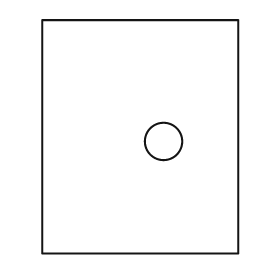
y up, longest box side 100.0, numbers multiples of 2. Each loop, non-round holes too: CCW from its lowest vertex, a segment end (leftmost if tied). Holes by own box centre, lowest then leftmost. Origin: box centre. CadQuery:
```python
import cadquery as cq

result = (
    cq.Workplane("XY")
    .moveTo(-42.0, -50.0)
    .lineTo(42.0, -50.0)
    .lineTo(42.0, 50.0)
    .lineTo(-42.0, 50.0)
    .close()
    .moveTo(10.0, -2.0)
    .circle(8.0)
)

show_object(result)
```